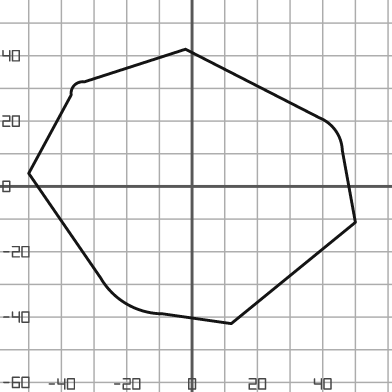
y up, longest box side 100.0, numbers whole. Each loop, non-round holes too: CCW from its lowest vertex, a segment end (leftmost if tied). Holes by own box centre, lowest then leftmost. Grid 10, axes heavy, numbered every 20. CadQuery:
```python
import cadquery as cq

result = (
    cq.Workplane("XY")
    .moveTo(12.0, -42.0)
    .lineTo(50.0, -11.0)
    .lineTo(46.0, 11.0)
    .threePointArc((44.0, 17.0), (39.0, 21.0))
    .lineTo(-2.0, 42.0)
    .lineTo(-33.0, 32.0)
    .threePointArc((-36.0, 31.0), (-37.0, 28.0))
    .lineTo(-50.0, 4.0)
    .lineTo(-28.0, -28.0)
    .threePointArc((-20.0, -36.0), (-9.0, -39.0))
    .close()
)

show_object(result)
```